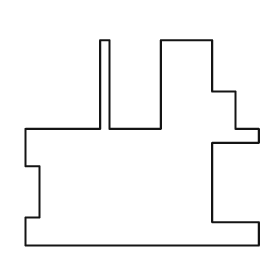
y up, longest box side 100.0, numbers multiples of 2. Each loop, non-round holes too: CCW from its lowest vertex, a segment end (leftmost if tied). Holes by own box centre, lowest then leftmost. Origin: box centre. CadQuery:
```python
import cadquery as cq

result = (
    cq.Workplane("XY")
    .moveTo(-50.0, -44.0)
    .lineTo(50.0, -44.0)
    .lineTo(50.0, -34.0)
    .lineTo(30.0, -34.0)
    .lineTo(30.0, 0.0)
    .lineTo(50.0, 0.0)
    .lineTo(50.0, 6.0)
    .lineTo(40.0, 6.0)
    .lineTo(40.0, 22.0)
    .lineTo(30.0, 22.0)
    .lineTo(30.0, 44.0)
    .lineTo(8.0, 44.0)
    .lineTo(8.0, 6.0)
    .lineTo(-14.0, 6.0)
    .lineTo(-14.0, 44.0)
    .lineTo(-18.0, 44.0)
    .lineTo(-18.0, 6.0)
    .lineTo(-50.0, 6.0)
    .lineTo(-50.0, -10.0)
    .lineTo(-44.0, -10.0)
    .lineTo(-44.0, -32.0)
    .lineTo(-50.0, -32.0)
    .close()
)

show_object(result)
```